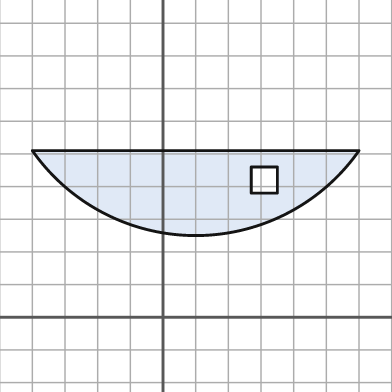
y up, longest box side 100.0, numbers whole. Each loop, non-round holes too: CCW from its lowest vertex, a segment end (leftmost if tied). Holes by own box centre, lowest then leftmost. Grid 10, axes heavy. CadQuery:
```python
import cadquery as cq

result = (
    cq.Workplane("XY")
    .moveTo(-40.0, 51.0)
    .threePointArc((10.0, 25.0), (60.0, 51.0))
    .close()
    .moveTo(27.0, 38.0)
    .lineTo(35.0, 38.0)
    .lineTo(35.0, 46.0)
    .lineTo(27.0, 46.0)
    .close()
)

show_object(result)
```